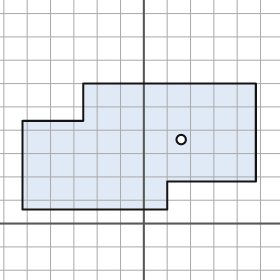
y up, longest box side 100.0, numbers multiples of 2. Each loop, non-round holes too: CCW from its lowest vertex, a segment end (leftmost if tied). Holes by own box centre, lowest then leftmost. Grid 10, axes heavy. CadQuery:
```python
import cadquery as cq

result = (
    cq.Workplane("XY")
    .moveTo(-52.0, 6.0)
    .lineTo(10.0, 6.0)
    .lineTo(10.0, 18.0)
    .lineTo(48.0, 18.0)
    .lineTo(48.0, 60.0)
    .lineTo(-26.0, 60.0)
    .lineTo(-26.0, 44.0)
    .lineTo(-52.0, 44.0)
    .close()
    .moveTo(16.0, 36.0)
    .circle(2.0)
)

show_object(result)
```